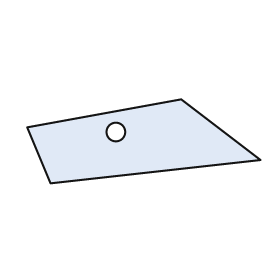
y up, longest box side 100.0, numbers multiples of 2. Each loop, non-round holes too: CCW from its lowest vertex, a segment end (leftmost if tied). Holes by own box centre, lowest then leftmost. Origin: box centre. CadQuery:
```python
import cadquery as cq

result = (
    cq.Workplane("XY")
    .moveTo(-40.0, -18.0)
    .lineTo(50.0, -8.0)
    .lineTo(16.0, 18.0)
    .lineTo(-50.0, 6.0)
    .close()
    .moveTo(-12.0, 4.0)
    .circle(4.0)
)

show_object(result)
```